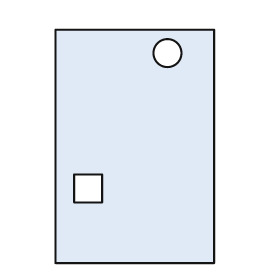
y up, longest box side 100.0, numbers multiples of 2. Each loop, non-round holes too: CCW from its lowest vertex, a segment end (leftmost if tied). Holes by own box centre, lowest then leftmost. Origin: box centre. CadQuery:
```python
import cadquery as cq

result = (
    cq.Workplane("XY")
    .moveTo(-34.0, -50.0)
    .lineTo(34.0, -50.0)
    .lineTo(34.0, 50.0)
    .lineTo(-34.0, 50.0)
    .close()
    .moveTo(-26.0, -24.0)
    .lineTo(-14.0, -24.0)
    .lineTo(-14.0, -12.0)
    .lineTo(-26.0, -12.0)
    .close()
    .moveTo(14.0, 40.0)
    .circle(6.0)
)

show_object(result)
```